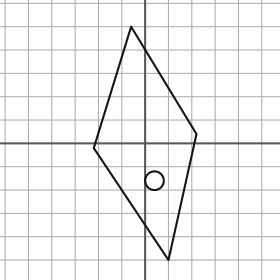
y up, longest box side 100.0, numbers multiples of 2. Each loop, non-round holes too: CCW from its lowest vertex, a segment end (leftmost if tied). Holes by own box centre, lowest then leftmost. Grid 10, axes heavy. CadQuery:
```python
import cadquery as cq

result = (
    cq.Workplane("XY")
    .moveTo(10.0, -50.0)
    .lineTo(22.0, 4.0)
    .lineTo(-6.0, 50.0)
    .lineTo(-22.0, -2.0)
    .close()
    .moveTo(4.0, -16.0)
    .circle(4.0)
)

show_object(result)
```